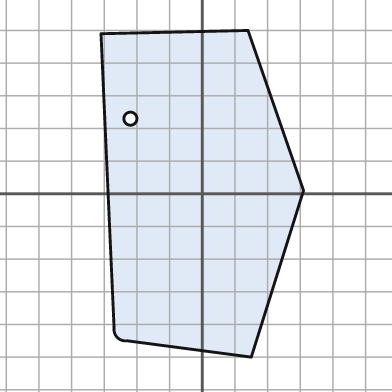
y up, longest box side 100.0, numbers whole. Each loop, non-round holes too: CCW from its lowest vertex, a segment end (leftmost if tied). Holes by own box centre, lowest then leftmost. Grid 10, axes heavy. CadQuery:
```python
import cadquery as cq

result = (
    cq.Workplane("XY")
    .moveTo(15.0, -50.0)
    .lineTo(31.0, 1.0)
    .lineTo(14.0, 50.0)
    .lineTo(-31.0, 49.0)
    .lineTo(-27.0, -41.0)
    .threePointArc((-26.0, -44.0), (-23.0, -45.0))
    .close()
    .moveTo(-22.0, 23.0)
    .circle(2.0)
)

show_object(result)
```